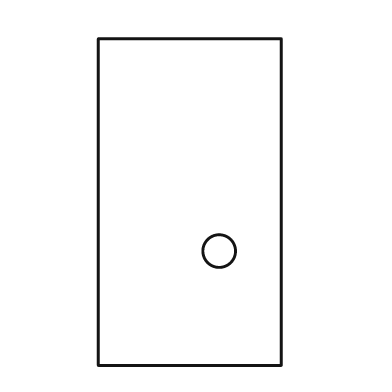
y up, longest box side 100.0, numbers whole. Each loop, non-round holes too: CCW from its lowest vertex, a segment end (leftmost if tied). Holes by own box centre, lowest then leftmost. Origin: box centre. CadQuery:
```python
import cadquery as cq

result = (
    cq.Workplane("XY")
    .moveTo(-28.0, -50.0)
    .lineTo(28.0, -50.0)
    .lineTo(28.0, 50.0)
    .lineTo(-28.0, 50.0)
    .close()
    .moveTo(9.0, -15.0)
    .circle(5.0)
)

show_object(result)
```